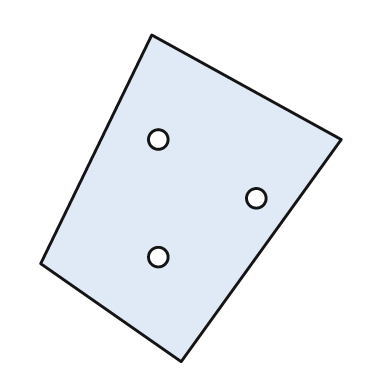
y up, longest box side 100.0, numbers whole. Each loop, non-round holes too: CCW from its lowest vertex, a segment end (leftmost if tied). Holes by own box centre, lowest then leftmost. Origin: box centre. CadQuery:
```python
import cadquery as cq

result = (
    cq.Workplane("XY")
    .moveTo(-3.0, -50.0)
    .lineTo(46.0, 18.0)
    .lineTo(-12.0, 50.0)
    .lineTo(-46.0, -20.0)
    .close()
    .moveTo(-10.0, -18.0)
    .circle(3.0)
    .moveTo(20.0, 0.0)
    .circle(3.0)
    .moveTo(-10.0, 18.0)
    .circle(3.0)
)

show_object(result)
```